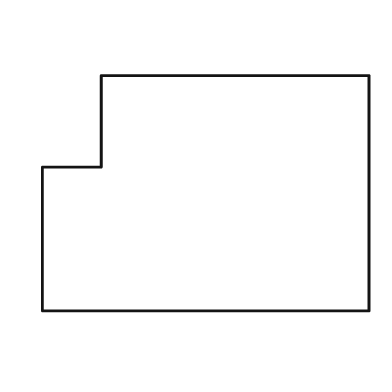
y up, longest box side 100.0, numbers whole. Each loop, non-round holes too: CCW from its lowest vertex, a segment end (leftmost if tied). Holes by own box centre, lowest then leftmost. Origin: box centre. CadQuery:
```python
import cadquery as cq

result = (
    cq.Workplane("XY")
    .moveTo(-50.0, -36.0)
    .lineTo(50.0, -36.0)
    .lineTo(50.0, 36.0)
    .lineTo(-32.0, 36.0)
    .lineTo(-32.0, 8.0)
    .lineTo(-50.0, 8.0)
    .close()
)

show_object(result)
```